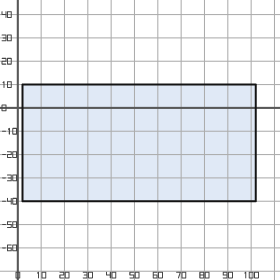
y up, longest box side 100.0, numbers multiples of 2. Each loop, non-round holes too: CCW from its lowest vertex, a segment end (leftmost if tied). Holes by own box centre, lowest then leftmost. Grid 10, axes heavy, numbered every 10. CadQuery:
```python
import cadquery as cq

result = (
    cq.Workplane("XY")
    .moveTo(2.0, -40.0)
    .lineTo(102.0, -40.0)
    .lineTo(102.0, 10.0)
    .lineTo(2.0, 10.0)
    .close()
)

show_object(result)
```